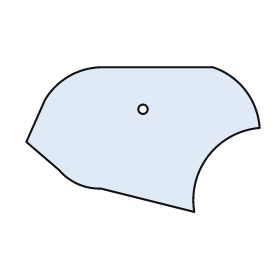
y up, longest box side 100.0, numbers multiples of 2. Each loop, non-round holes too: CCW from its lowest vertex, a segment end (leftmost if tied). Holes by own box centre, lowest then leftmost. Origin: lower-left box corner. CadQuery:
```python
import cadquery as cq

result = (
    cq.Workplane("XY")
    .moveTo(72.0, 0.0)
    .threePointArc((78.0, 24.0), (100.0, 36.0))
    .threePointArc((94.0, 52.0), (80.0, 62.0))
    .lineTo(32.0, 62.0)
    .threePointArc((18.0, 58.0), (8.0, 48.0))
    .lineTo(0.0, 30.0)
    .lineTo(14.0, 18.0)
    .threePointArc((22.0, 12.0), (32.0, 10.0))
    .close()
    .moveTo(50.0, 44.0)
    .circle(2.0)
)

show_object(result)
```